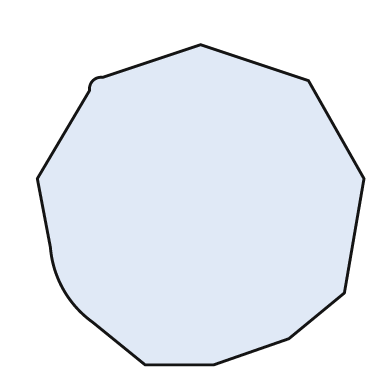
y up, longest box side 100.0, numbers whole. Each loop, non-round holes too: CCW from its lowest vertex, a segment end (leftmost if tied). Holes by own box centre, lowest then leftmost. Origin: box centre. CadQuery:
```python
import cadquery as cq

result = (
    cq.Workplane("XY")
    .moveTo(-17.0, -49.0)
    .lineTo(4.0, -49.0)
    .lineTo(27.0, -41.0)
    .lineTo(44.0, -27.0)
    .lineTo(50.0, 8.0)
    .lineTo(33.0, 38.0)
    .lineTo(0.0, 49.0)
    .lineTo(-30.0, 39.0)
    .threePointArc((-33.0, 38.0), (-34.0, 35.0))
    .lineTo(-50.0, 8.0)
    .lineTo(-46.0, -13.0)
    .threePointArc((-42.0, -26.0), (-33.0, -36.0))
    .close()
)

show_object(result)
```